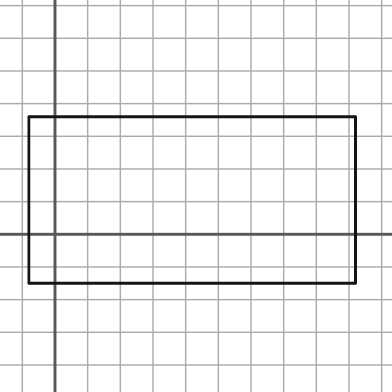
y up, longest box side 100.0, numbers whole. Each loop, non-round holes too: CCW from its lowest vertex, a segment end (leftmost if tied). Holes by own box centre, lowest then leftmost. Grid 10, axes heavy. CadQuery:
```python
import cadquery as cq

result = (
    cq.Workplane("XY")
    .moveTo(-8.0, -15.0)
    .lineTo(92.0, -15.0)
    .lineTo(92.0, 36.0)
    .lineTo(-8.0, 36.0)
    .close()
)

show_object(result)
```